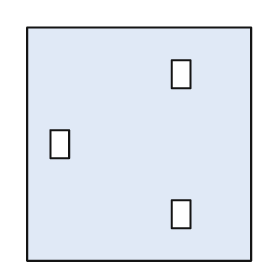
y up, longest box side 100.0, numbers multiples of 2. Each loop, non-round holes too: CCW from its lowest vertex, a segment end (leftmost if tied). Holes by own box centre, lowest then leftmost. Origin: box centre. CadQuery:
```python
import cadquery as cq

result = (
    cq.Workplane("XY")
    .moveTo(-48.0, -50.0)
    .lineTo(48.0, -50.0)
    .lineTo(48.0, 50.0)
    .lineTo(-48.0, 50.0)
    .close()
    .moveTo(14.0, -36.0)
    .lineTo(22.0, -36.0)
    .lineTo(22.0, -24.0)
    .lineTo(14.0, -24.0)
    .close()
    .moveTo(-38.0, -6.0)
    .lineTo(-30.0, -6.0)
    .lineTo(-30.0, 6.0)
    .lineTo(-38.0, 6.0)
    .close()
    .moveTo(14.0, 24.0)
    .lineTo(22.0, 24.0)
    .lineTo(22.0, 36.0)
    .lineTo(14.0, 36.0)
    .close()
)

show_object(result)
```